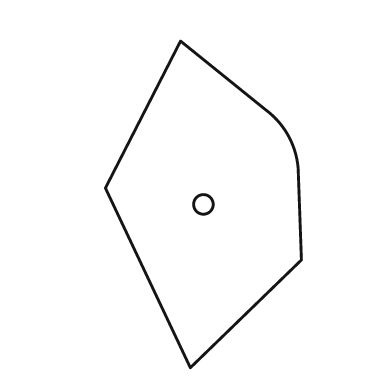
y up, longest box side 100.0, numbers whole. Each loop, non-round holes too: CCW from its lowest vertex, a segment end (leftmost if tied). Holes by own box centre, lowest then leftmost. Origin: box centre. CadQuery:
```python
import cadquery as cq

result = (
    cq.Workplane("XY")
    .moveTo(-4.0, -50.0)
    .lineTo(30.0, -17.0)
    .lineTo(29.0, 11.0)
    .threePointArc((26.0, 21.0), (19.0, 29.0))
    .lineTo(-7.0, 50.0)
    .lineTo(-30.0, 5.0)
    .close()
    .moveTo(0.0, 0.0)
    .circle(3.0)
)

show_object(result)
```